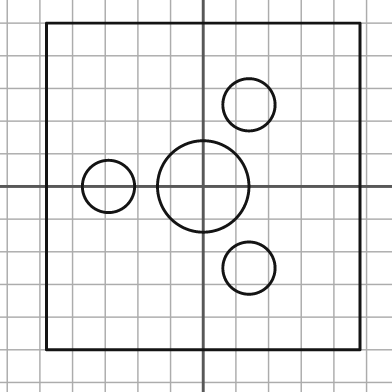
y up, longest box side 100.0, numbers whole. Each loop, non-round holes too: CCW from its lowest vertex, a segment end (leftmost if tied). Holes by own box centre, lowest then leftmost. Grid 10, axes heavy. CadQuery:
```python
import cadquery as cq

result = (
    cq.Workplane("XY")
    .moveTo(-48.0, -50.0)
    .lineTo(48.0, -50.0)
    .lineTo(48.0, 50.0)
    .lineTo(-48.0, 50.0)
    .close()
    .moveTo(14.0, -25.0)
    .circle(8.0)
    .moveTo(-29.0, 0.0)
    .circle(8.0)
    .moveTo(0.0, 0.0)
    .circle(14.0)
    .moveTo(14.0, 25.0)
    .circle(8.0)
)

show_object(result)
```